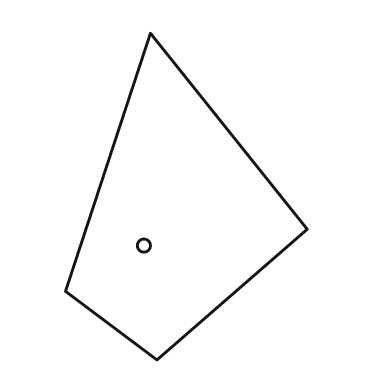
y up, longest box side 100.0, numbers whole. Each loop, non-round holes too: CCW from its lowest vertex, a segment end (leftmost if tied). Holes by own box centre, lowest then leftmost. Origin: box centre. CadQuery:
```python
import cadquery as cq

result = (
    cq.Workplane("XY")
    .moveTo(-9.0, -50.0)
    .lineTo(37.0, -10.0)
    .lineTo(-11.0, 50.0)
    .lineTo(-37.0, -29.0)
    .close()
    .moveTo(-13.0, -15.0)
    .circle(2.0)
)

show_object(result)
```